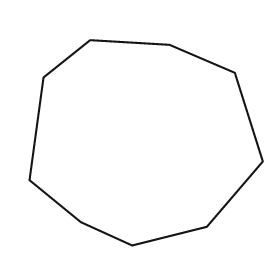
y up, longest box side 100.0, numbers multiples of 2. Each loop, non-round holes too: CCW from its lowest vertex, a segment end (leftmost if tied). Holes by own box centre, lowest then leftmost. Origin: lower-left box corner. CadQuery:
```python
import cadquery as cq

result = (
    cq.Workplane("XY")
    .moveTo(44.0, 0.0)
    .lineTo(76.0, 8.0)
    .lineTo(100.0, 36.0)
    .lineTo(88.0, 74.0)
    .lineTo(60.0, 86.0)
    .lineTo(26.0, 88.0)
    .lineTo(6.0, 72.0)
    .lineTo(0.0, 28.0)
    .lineTo(22.0, 10.0)
    .close()
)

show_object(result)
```